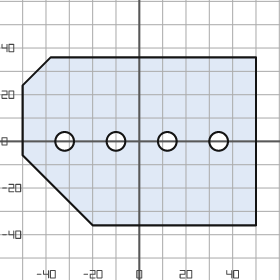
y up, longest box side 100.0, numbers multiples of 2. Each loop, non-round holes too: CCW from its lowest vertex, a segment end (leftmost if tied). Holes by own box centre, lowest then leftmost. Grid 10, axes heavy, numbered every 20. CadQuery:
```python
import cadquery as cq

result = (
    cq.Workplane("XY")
    .moveTo(-20.0, -36.0)
    .lineTo(50.0, -36.0)
    .lineTo(50.0, 36.0)
    .lineTo(-38.0, 36.0)
    .lineTo(-50.0, 24.0)
    .lineTo(-50.0, -6.0)
    .close()
    .moveTo(-32.0, 0.0)
    .circle(4.0)
    .moveTo(-10.0, 0.0)
    .circle(4.0)
    .moveTo(12.0, 0.0)
    .circle(4.0)
    .moveTo(34.0, 0.0)
    .circle(4.0)
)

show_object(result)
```